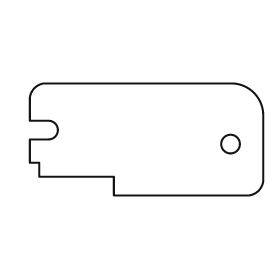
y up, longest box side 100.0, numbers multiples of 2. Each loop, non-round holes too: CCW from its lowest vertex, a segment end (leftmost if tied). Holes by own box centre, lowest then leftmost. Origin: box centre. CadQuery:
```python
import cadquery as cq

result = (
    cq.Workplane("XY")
    .moveTo(-14.0, -24.0)
    .lineTo(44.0, -24.0)
    .threePointArc((48.0, -22.0), (50.0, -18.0))
    .lineTo(50.0, 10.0)
    .threePointArc((46.0, 20.0), (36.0, 24.0))
    .lineTo(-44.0, 24.0)
    .threePointArc((-48.0, 22.0), (-50.0, 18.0))
    .lineTo(-50.0, 8.0)
    .lineTo(-42.0, 8.0)
    .threePointArc((-38.0, 4.0), (-42.0, 0.0))
    .lineTo(-50.0, 0.0)
    .lineTo(-50.0, -10.0)
    .lineTo(-46.0, -10.0)
    .lineTo(-46.0, -16.0)
    .lineTo(-14.0, -16.0)
    .close()
    .moveTo(36.0, -2.0)
    .circle(4.0)
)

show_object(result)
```